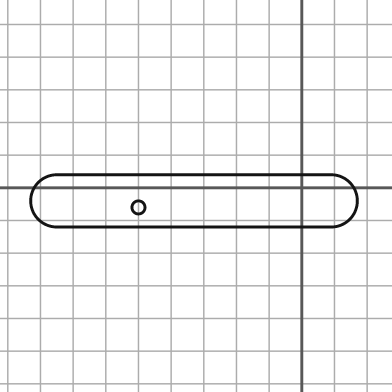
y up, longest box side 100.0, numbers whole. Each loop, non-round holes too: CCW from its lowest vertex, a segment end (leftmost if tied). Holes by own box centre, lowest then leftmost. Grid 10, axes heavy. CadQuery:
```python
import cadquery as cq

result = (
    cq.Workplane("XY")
    .moveTo(-75.0, -12.0)
    .lineTo(9.0, -12.0)
    .threePointArc((17.0, -4.0), (9.0, 4.0))
    .lineTo(-75.0, 4.0)
    .threePointArc((-83.0, -4.0), (-75.0, -12.0))
    .close()
    .moveTo(-50.0, -6.0)
    .circle(2.0)
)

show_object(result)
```